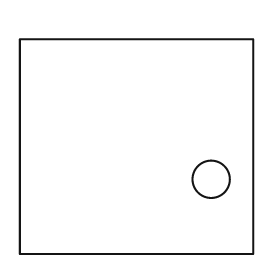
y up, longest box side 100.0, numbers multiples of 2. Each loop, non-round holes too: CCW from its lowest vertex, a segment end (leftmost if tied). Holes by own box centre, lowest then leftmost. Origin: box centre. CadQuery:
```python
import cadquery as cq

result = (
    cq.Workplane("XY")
    .moveTo(-50.0, -46.0)
    .lineTo(50.0, -46.0)
    .lineTo(50.0, 46.0)
    .lineTo(-50.0, 46.0)
    .close()
    .moveTo(32.0, -14.0)
    .circle(8.0)
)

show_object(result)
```